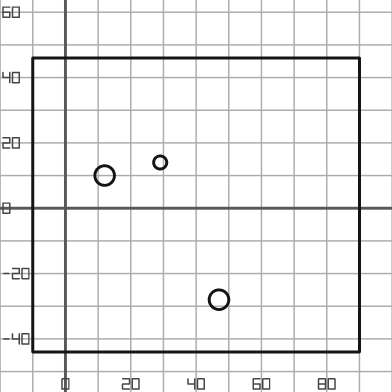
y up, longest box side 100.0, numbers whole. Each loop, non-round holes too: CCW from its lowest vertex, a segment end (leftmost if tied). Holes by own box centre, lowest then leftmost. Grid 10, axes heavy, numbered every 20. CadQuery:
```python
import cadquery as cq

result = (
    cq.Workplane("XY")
    .moveTo(-10.0, -44.0)
    .lineTo(90.0, -44.0)
    .lineTo(90.0, 46.0)
    .lineTo(-10.0, 46.0)
    .close()
    .moveTo(47.0, -28.0)
    .circle(3.0)
    .moveTo(12.0, 10.0)
    .circle(3.0)
    .moveTo(29.0, 14.0)
    .circle(2.0)
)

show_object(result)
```